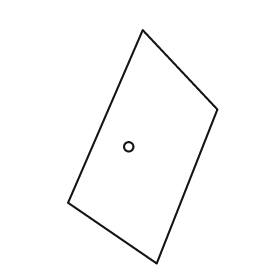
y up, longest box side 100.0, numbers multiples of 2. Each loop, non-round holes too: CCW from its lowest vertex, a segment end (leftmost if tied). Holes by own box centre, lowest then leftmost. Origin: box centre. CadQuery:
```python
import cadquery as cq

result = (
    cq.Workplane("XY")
    .moveTo(6.0, -50.0)
    .lineTo(32.0, 16.0)
    .lineTo(0.0, 50.0)
    .lineTo(-32.0, -24.0)
    .close()
    .moveTo(-6.0, 0.0)
    .circle(2.0)
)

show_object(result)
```